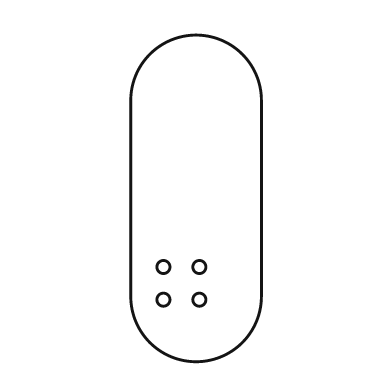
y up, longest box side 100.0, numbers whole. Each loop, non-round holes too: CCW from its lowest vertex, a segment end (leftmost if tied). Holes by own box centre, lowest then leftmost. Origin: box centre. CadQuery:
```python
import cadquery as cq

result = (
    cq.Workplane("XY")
    .moveTo(-20.0, -30.0)
    .threePointArc((0.0, -50.0), (20.0, -30.0))
    .lineTo(20.0, 30.0)
    .threePointArc((0.0, 50.0), (-20.0, 30.0))
    .close()
    .moveTo(-10.0, -31.0)
    .circle(2.0)
    .moveTo(1.0, -31.0)
    .circle(2.0)
    .moveTo(-10.0, -21.0)
    .circle(2.0)
    .moveTo(1.0, -21.0)
    .circle(2.0)
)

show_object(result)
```